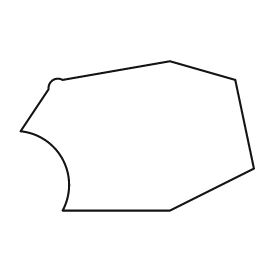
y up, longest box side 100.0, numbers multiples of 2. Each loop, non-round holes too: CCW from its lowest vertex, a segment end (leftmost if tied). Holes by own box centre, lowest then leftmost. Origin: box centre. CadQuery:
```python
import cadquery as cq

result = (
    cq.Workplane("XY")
    .moveTo(-32.0, -32.0)
    .lineTo(14.0, -32.0)
    .lineTo(50.0, -14.0)
    .lineTo(42.0, 24.0)
    .lineTo(14.0, 32.0)
    .lineTo(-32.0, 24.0)
    .threePointArc((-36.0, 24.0), (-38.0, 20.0))
    .lineTo(-50.0, 2.0)
    .threePointArc((-32.0, -10.0), (-32.0, -32.0))
    .close()
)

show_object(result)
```